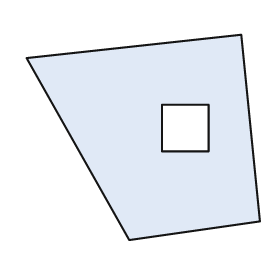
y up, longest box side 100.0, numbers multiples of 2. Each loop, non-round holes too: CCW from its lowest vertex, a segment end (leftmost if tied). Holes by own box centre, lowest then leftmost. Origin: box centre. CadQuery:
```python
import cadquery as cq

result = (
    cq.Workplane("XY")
    .moveTo(-6.0, -44.0)
    .lineTo(50.0, -36.0)
    .lineTo(42.0, 44.0)
    .lineTo(-50.0, 34.0)
    .close()
    .moveTo(8.0, -6.0)
    .lineTo(28.0, -6.0)
    .lineTo(28.0, 14.0)
    .lineTo(8.0, 14.0)
    .close()
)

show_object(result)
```